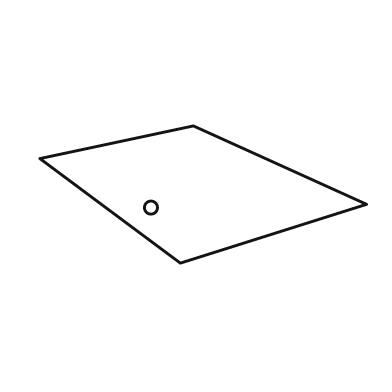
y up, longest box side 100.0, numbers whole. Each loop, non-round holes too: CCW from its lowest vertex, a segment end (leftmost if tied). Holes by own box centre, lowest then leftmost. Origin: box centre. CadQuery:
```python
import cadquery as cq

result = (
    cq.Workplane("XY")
    .moveTo(-7.0, -21.0)
    .lineTo(50.0, -3.0)
    .lineTo(-3.0, 21.0)
    .lineTo(-50.0, 11.0)
    .close()
    .moveTo(-16.0, -4.0)
    .circle(2.0)
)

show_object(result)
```